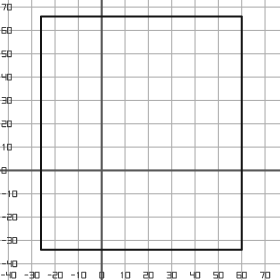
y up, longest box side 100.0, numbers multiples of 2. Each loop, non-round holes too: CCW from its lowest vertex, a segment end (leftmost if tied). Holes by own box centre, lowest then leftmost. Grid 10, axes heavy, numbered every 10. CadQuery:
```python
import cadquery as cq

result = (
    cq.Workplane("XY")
    .moveTo(-26.0, -34.0)
    .lineTo(60.0, -34.0)
    .lineTo(60.0, 66.0)
    .lineTo(-26.0, 66.0)
    .close()
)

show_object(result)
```